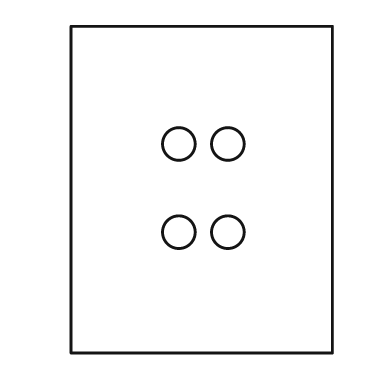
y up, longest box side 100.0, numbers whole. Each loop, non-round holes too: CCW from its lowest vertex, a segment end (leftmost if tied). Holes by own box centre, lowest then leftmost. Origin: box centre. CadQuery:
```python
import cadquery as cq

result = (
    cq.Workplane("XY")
    .moveTo(-40.0, -50.0)
    .lineTo(40.0, -50.0)
    .lineTo(40.0, 50.0)
    .lineTo(-40.0, 50.0)
    .close()
    .moveTo(-7.0, -13.0)
    .circle(5.0)
    .moveTo(8.0, -13.0)
    .circle(5.0)
    .moveTo(-7.0, 14.0)
    .circle(5.0)
    .moveTo(8.0, 14.0)
    .circle(5.0)
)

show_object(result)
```